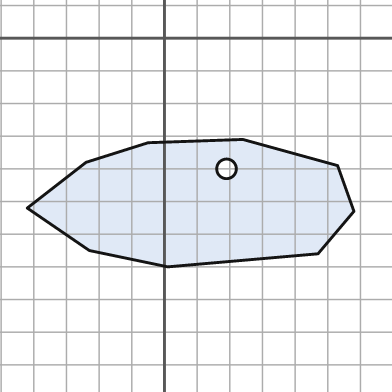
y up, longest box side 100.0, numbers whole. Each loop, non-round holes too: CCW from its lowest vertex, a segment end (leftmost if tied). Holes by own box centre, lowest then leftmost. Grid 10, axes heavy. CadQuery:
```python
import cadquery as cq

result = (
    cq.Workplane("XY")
    .moveTo(1.0, -70.0)
    .lineTo(47.0, -66.0)
    .lineTo(58.0, -53.0)
    .lineTo(53.0, -39.0)
    .lineTo(24.0, -31.0)
    .lineTo(-5.0, -32.0)
    .lineTo(-24.0, -38.0)
    .lineTo(-42.0, -52.0)
    .lineTo(-23.0, -65.0)
    .close()
    .moveTo(19.0, -40.0)
    .circle(3.0)
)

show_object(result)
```